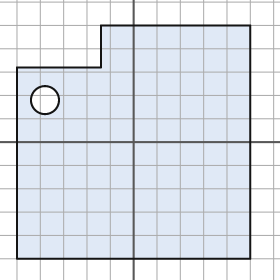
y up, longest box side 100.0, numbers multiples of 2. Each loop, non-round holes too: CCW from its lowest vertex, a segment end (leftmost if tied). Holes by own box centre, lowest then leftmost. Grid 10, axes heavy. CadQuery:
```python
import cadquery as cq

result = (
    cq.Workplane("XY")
    .moveTo(-50.0, -50.0)
    .lineTo(50.0, -50.0)
    .lineTo(50.0, 50.0)
    .lineTo(-14.0, 50.0)
    .lineTo(-14.0, 32.0)
    .lineTo(-50.0, 32.0)
    .close()
    .moveTo(-38.0, 18.0)
    .circle(6.0)
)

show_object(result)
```